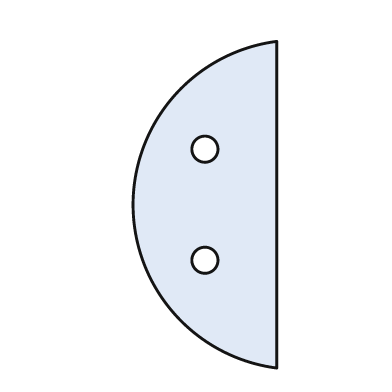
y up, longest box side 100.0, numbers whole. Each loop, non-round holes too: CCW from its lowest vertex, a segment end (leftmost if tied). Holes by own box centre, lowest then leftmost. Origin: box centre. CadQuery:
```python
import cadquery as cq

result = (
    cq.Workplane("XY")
    .moveTo(22.0, -50.0)
    .lineTo(22.0, 50.0)
    .threePointArc((-22.0, 0.0), (22.0, -50.0))
    .close()
    .moveTo(0.0, -17.0)
    .circle(4.0)
    .moveTo(0.0, 17.0)
    .circle(4.0)
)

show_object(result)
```